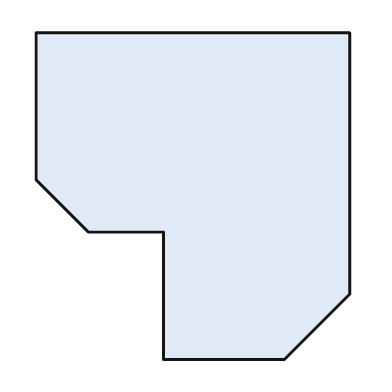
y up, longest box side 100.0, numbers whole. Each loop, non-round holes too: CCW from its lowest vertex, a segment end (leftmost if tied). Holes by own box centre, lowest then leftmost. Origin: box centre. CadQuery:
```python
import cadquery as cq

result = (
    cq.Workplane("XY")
    .moveTo(-9.0, -50.0)
    .lineTo(28.0, -50.0)
    .lineTo(48.0, -30.0)
    .lineTo(48.0, 50.0)
    .lineTo(-48.0, 50.0)
    .lineTo(-48.0, 5.0)
    .lineTo(-32.0, -11.0)
    .lineTo(-9.0, -11.0)
    .close()
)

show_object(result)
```